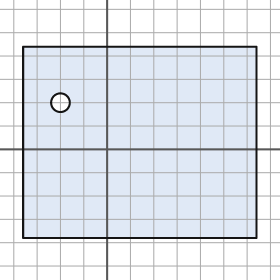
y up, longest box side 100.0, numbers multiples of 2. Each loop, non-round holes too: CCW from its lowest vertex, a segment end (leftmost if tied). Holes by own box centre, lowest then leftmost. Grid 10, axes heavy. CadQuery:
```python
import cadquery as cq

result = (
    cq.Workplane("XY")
    .moveTo(-36.0, -38.0)
    .lineTo(64.0, -38.0)
    .lineTo(64.0, 44.0)
    .lineTo(-36.0, 44.0)
    .close()
    .moveTo(-20.0, 20.0)
    .circle(4.0)
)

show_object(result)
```